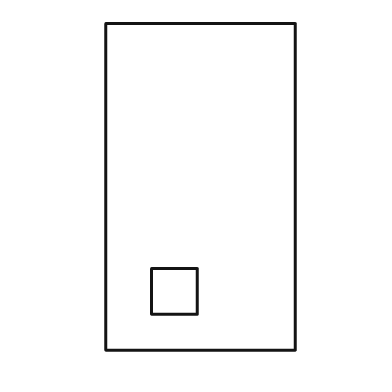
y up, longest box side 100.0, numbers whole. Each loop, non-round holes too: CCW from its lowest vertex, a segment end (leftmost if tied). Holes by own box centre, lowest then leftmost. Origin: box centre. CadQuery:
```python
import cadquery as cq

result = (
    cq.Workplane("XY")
    .moveTo(-29.0, -50.0)
    .lineTo(29.0, -50.0)
    .lineTo(29.0, 50.0)
    .lineTo(-29.0, 50.0)
    .close()
    .moveTo(-15.0, -39.0)
    .lineTo(-1.0, -39.0)
    .lineTo(-1.0, -25.0)
    .lineTo(-15.0, -25.0)
    .close()
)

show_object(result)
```